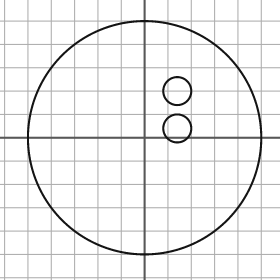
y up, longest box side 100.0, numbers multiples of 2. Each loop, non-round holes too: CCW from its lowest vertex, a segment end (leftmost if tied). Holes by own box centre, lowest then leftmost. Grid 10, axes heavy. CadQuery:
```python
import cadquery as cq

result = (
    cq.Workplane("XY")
    .moveTo(0.0, 0.0)
    .circle(50.0)
    .moveTo(14.0, 4.0)
    .circle(6.0)
    .moveTo(14.0, 20.0)
    .circle(6.0)
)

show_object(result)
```